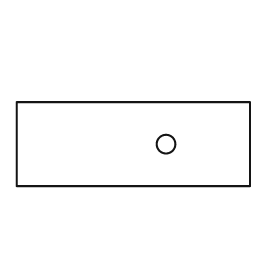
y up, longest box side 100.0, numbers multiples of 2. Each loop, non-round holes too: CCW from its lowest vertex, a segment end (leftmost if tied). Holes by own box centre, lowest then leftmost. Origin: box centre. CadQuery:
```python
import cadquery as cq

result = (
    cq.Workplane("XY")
    .moveTo(-50.0, -18.0)
    .lineTo(50.0, -18.0)
    .lineTo(50.0, 18.0)
    .lineTo(-50.0, 18.0)
    .close()
    .moveTo(14.0, 0.0)
    .circle(4.0)
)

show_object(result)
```